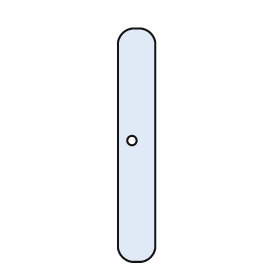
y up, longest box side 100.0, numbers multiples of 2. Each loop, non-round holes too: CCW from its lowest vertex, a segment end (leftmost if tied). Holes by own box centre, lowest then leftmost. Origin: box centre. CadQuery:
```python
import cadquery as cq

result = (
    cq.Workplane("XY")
    .moveTo(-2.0, -50.0)
    .lineTo(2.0, -50.0)
    .threePointArc((6.0, -48.0), (8.0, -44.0))
    .lineTo(8.0, 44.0)
    .threePointArc((6.0, 48.0), (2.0, 50.0))
    .lineTo(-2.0, 50.0)
    .threePointArc((-6.0, 48.0), (-8.0, 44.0))
    .lineTo(-8.0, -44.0)
    .threePointArc((-6.0, -48.0), (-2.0, -50.0))
    .close()
    .moveTo(-2.0, 2.0)
    .circle(2.0)
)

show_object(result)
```